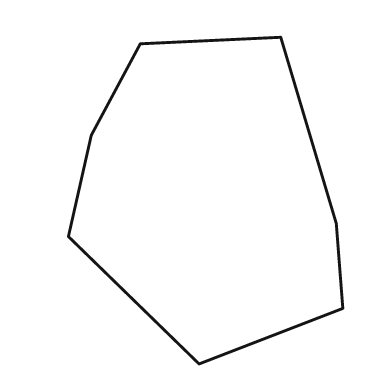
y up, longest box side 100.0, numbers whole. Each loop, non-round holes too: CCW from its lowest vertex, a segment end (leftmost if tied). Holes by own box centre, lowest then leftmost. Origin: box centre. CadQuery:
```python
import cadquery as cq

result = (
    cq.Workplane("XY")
    .moveTo(-2.0, -50.0)
    .lineTo(42.0, -33.0)
    .lineTo(40.0, -7.0)
    .lineTo(23.0, 50.0)
    .lineTo(-20.0, 48.0)
    .lineTo(-35.0, 20.0)
    .lineTo(-42.0, -11.0)
    .close()
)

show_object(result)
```